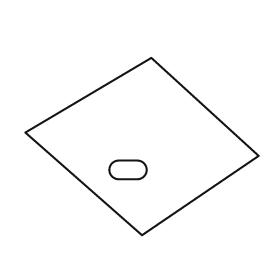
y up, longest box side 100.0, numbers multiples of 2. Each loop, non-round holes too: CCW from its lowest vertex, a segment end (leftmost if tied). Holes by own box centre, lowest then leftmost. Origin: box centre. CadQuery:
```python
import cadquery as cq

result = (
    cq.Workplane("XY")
    .moveTo(0.0, -38.0)
    .lineTo(50.0, -4.0)
    .lineTo(4.0, 38.0)
    .lineTo(-50.0, 6.0)
    .close()
    .moveTo(-10.0, -14.0)
    .lineTo(-2.0, -14.0)
    .threePointArc((2.0, -10.0), (-2.0, -6.0))
    .lineTo(-10.0, -6.0)
    .threePointArc((-14.0, -10.0), (-10.0, -14.0))
    .close()
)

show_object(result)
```